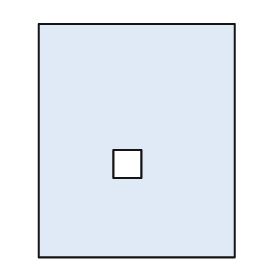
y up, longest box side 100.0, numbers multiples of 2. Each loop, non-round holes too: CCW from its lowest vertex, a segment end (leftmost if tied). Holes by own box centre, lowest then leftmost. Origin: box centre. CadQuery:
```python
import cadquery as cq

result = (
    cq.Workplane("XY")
    .moveTo(-42.0, -50.0)
    .lineTo(42.0, -50.0)
    .lineTo(42.0, 50.0)
    .lineTo(-42.0, 50.0)
    .close()
    .moveTo(-10.0, -16.0)
    .lineTo(2.0, -16.0)
    .lineTo(2.0, -4.0)
    .lineTo(-10.0, -4.0)
    .close()
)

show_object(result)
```